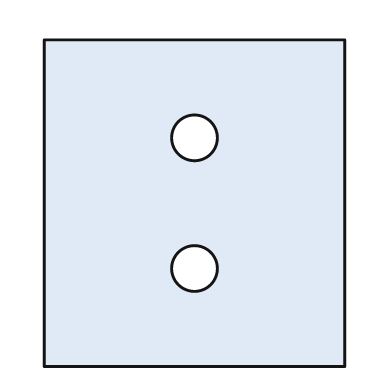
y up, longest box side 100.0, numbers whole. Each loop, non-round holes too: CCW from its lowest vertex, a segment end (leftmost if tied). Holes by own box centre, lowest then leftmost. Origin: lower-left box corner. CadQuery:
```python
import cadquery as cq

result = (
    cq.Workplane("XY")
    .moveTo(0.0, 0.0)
    .lineTo(92.0, 0.0)
    .lineTo(92.0, 100.0)
    .lineTo(0.0, 100.0)
    .close()
    .moveTo(46.0, 30.0)
    .circle(7.0)
    .moveTo(46.0, 70.0)
    .circle(7.0)
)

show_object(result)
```